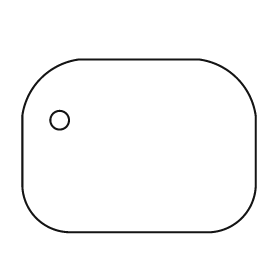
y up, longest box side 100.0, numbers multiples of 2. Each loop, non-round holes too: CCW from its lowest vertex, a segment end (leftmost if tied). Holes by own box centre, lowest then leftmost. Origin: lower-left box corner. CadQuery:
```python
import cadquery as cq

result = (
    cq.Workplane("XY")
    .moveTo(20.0, 0.0)
    .lineTo(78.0, 0.0)
    .threePointArc((94.0, 6.0), (100.0, 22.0))
    .lineTo(100.0, 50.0)
    .threePointArc((92.0, 66.0), (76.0, 74.0))
    .lineTo(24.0, 74.0)
    .threePointArc((8.0, 66.0), (0.0, 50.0))
    .lineTo(0.0, 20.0)
    .threePointArc((6.0, 6.0), (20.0, 0.0))
    .close()
    .moveTo(16.0, 48.0)
    .circle(4.0)
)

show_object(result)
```